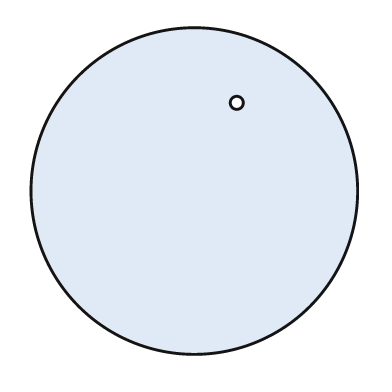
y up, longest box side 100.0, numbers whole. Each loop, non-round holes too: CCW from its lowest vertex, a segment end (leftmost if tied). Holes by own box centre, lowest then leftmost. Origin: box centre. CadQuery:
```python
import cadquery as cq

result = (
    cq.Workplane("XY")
    .moveTo(0.0, 0.0)
    .circle(50.0)
    .moveTo(13.0, 27.0)
    .circle(2.0)
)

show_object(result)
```